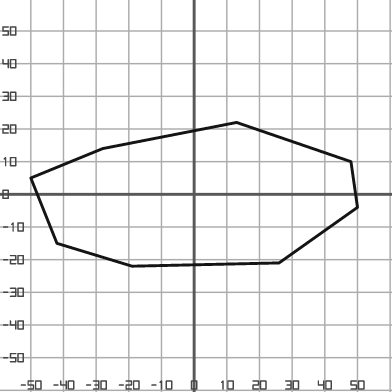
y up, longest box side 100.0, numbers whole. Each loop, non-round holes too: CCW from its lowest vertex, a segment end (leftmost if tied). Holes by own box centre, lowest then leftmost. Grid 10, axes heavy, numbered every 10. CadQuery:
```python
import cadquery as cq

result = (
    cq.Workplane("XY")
    .moveTo(-19.0, -22.0)
    .lineTo(26.0, -21.0)
    .lineTo(50.0, -4.0)
    .lineTo(48.0, 10.0)
    .lineTo(13.0, 22.0)
    .lineTo(-28.0, 14.0)
    .lineTo(-50.0, 5.0)
    .lineTo(-42.0, -15.0)
    .close()
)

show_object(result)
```